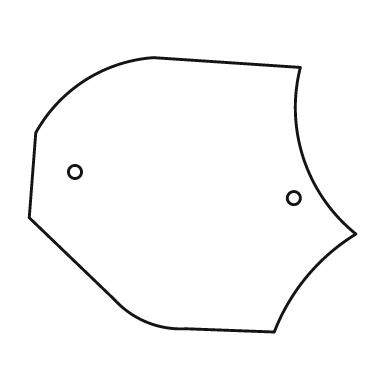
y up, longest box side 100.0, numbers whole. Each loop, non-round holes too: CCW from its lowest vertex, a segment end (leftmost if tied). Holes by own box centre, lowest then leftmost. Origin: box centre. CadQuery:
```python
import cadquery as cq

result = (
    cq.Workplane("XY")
    .moveTo(25.0, -42.0)
    .threePointArc((35.0, -25.0), (50.0, -12.0))
    .threePointArc((34.0, 11.0), (33.0, 39.0))
    .lineTo(-12.0, 42.0)
    .threePointArc((-33.0, 35.0), (-48.0, 19.0))
    .lineTo(-50.0, -7.0)
    .lineTo(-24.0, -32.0)
    .threePointArc((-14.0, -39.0), (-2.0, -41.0))
    .close()
    .moveTo(31.0, -1.0)
    .circle(2.0)
    .moveTo(-36.0, 7.0)
    .circle(2.0)
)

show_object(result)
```